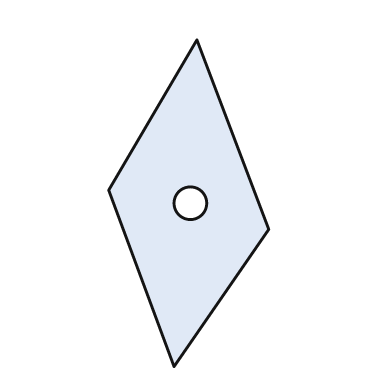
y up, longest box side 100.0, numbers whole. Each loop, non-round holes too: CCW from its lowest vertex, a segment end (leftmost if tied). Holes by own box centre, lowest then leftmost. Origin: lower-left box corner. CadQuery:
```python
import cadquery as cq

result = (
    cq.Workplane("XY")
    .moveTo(20.0, 0.0)
    .lineTo(49.0, 42.0)
    .lineTo(27.0, 100.0)
    .lineTo(0.0, 54.0)
    .close()
    .moveTo(25.0, 50.0)
    .circle(5.0)
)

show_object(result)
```